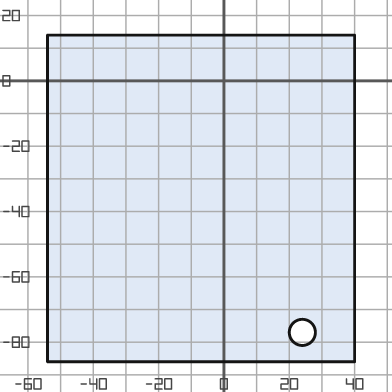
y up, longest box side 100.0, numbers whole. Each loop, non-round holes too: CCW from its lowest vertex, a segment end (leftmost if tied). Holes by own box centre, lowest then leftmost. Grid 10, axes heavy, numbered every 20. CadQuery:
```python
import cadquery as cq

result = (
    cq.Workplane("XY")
    .moveTo(-54.0, -86.0)
    .lineTo(40.0, -86.0)
    .lineTo(40.0, 14.0)
    .lineTo(-54.0, 14.0)
    .close()
    .moveTo(24.0, -77.0)
    .circle(4.0)
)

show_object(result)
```